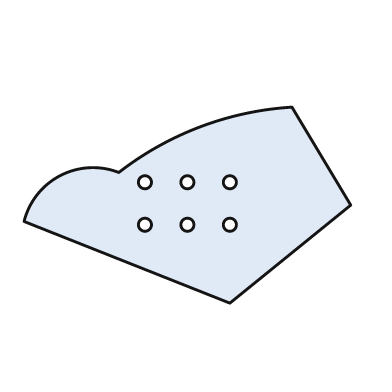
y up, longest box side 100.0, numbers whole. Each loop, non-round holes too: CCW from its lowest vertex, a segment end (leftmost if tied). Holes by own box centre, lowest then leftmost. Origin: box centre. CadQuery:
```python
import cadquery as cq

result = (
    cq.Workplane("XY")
    .moveTo(13.0, -30.0)
    .lineTo(50.0, 0.0)
    .lineTo(32.0, 30.0)
    .threePointArc((4.0, 24.0), (-21.0, 10.0))
    .threePointArc((-39.0, 9.0), (-50.0, -5.0))
    .close()
    .moveTo(-13.0, -6.0)
    .circle(2.0)
    .moveTo(0.0, -6.0)
    .circle(2.0)
    .moveTo(13.0, -6.0)
    .circle(2.0)
    .moveTo(-13.0, 7.0)
    .circle(2.0)
    .moveTo(0.0, 7.0)
    .circle(2.0)
    .moveTo(13.0, 7.0)
    .circle(2.0)
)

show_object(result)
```